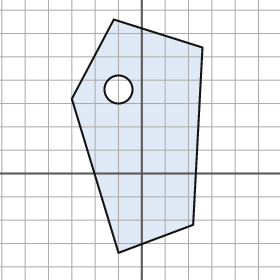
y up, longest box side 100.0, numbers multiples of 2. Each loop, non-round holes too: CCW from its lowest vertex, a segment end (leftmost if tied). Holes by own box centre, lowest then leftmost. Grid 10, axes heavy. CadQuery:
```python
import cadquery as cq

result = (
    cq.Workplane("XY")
    .moveTo(-10.0, -34.0)
    .lineTo(22.0, -22.0)
    .lineTo(26.0, 54.0)
    .lineTo(-12.0, 66.0)
    .lineTo(-30.0, 32.0)
    .close()
    .moveTo(-10.0, 36.0)
    .circle(6.0)
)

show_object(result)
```